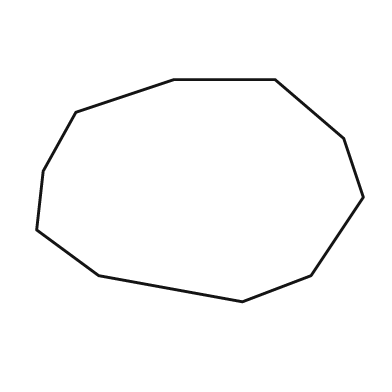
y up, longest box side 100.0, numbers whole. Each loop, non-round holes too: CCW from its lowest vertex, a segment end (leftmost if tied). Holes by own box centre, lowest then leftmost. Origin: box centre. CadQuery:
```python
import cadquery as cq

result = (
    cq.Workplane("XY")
    .moveTo(13.0, -34.0)
    .lineTo(34.0, -26.0)
    .lineTo(50.0, -2.0)
    .lineTo(44.0, 16.0)
    .lineTo(23.0, 34.0)
    .lineTo(-8.0, 34.0)
    .lineTo(-38.0, 24.0)
    .lineTo(-48.0, 6.0)
    .lineTo(-50.0, -12.0)
    .lineTo(-31.0, -26.0)
    .close()
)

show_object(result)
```